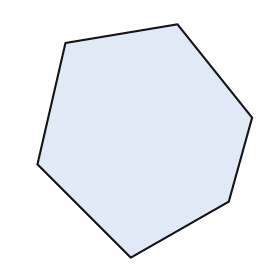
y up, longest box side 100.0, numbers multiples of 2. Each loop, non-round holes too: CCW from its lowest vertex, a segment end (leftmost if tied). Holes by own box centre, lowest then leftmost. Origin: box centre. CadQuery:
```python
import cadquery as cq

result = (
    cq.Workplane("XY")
    .moveTo(-6.0, -50.0)
    .lineTo(36.0, -26.0)
    .lineTo(46.0, 10.0)
    .lineTo(14.0, 50.0)
    .lineTo(-34.0, 42.0)
    .lineTo(-46.0, -10.0)
    .close()
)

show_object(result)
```